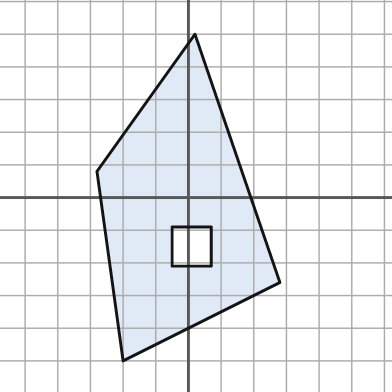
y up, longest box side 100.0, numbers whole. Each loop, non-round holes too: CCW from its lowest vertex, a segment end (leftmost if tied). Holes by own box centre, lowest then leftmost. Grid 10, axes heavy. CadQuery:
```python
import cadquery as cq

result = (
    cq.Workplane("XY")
    .moveTo(-20.0, -50.0)
    .lineTo(28.0, -26.0)
    .lineTo(2.0, 50.0)
    .lineTo(-28.0, 8.0)
    .close()
    .moveTo(-5.0, -21.0)
    .lineTo(7.0, -21.0)
    .lineTo(7.0, -9.0)
    .lineTo(-5.0, -9.0)
    .close()
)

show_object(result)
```